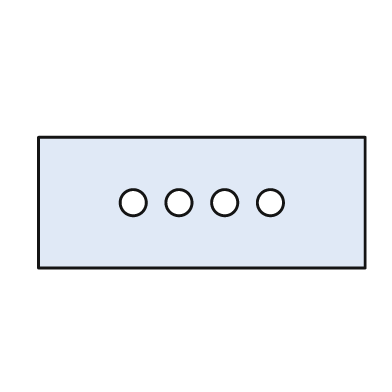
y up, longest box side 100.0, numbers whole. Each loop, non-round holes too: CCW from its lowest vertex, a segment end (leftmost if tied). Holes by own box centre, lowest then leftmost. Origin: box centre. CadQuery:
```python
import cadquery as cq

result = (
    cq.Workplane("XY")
    .moveTo(-50.0, -20.0)
    .lineTo(50.0, -20.0)
    .lineTo(50.0, 20.0)
    .lineTo(-50.0, 20.0)
    .close()
    .moveTo(-21.0, 0.0)
    .circle(4.0)
    .moveTo(-7.0, 0.0)
    .circle(4.0)
    .moveTo(7.0, 0.0)
    .circle(4.0)
    .moveTo(21.0, 0.0)
    .circle(4.0)
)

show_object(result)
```